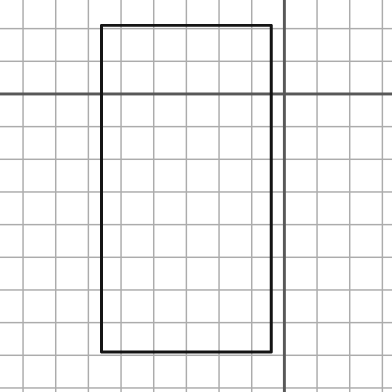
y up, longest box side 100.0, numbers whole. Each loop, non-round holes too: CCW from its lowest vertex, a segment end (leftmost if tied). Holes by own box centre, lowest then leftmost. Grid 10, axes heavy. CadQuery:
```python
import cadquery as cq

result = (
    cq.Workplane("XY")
    .moveTo(-56.0, -79.0)
    .lineTo(-4.0, -79.0)
    .lineTo(-4.0, 21.0)
    .lineTo(-56.0, 21.0)
    .close()
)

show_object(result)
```